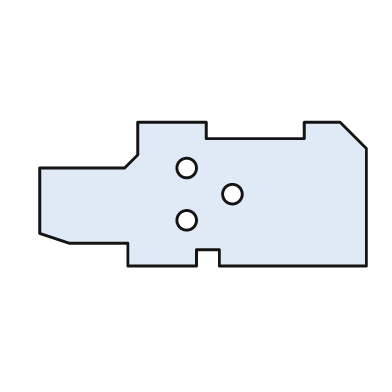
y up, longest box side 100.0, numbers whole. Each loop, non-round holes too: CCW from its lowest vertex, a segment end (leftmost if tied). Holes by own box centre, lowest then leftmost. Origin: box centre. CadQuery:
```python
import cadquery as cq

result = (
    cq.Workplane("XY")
    .moveTo(-23.0, -22.0)
    .lineTo(-2.0, -22.0)
    .lineTo(-2.0, -17.0)
    .lineTo(5.0, -17.0)
    .lineTo(5.0, -22.0)
    .lineTo(50.0, -22.0)
    .lineTo(50.0, 14.0)
    .lineTo(42.0, 22.0)
    .lineTo(31.0, 22.0)
    .lineTo(31.0, 17.0)
    .lineTo(1.0, 17.0)
    .lineTo(1.0, 22.0)
    .lineTo(-20.0, 22.0)
    .lineTo(-20.0, 12.0)
    .lineTo(-24.0, 8.0)
    .lineTo(-50.0, 8.0)
    .lineTo(-50.0, -12.0)
    .lineTo(-41.0, -15.0)
    .lineTo(-23.0, -15.0)
    .close()
    .moveTo(-5.0, -8.0)
    .circle(3.0)
    .moveTo(9.0, 0.0)
    .circle(3.0)
    .moveTo(-5.0, 8.0)
    .circle(3.0)
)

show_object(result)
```